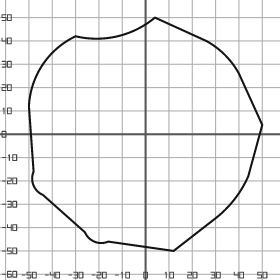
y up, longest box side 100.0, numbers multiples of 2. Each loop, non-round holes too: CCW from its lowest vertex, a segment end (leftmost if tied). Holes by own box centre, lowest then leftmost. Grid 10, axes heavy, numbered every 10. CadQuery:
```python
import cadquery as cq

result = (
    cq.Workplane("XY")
    .moveTo(12.0, -50.0)
    .lineTo(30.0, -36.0)
    .threePointArc((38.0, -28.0), (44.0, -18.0))
    .lineTo(50.0, 4.0)
    .lineTo(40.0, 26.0)
    .threePointArc((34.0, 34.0), (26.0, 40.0))
    .lineTo(4.0, 50.0)
    .threePointArc((-12.0, 42.0), (-30.0, 42.0))
    .threePointArc((-44.0, 30.0), (-50.0, 12.0))
    .lineTo(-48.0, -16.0)
    .threePointArc((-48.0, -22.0), (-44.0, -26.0))
    .lineTo(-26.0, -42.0)
    .threePointArc((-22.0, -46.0), (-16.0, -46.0))
    .close()
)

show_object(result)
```